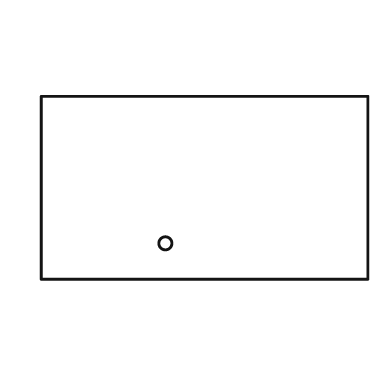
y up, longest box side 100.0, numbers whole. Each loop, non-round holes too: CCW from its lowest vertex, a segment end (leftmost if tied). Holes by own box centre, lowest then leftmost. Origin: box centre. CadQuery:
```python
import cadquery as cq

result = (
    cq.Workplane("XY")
    .moveTo(-50.0, -28.0)
    .lineTo(50.0, -28.0)
    .lineTo(50.0, 28.0)
    .lineTo(-50.0, 28.0)
    .close()
    .moveTo(-12.0, -17.0)
    .circle(2.0)
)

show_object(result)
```